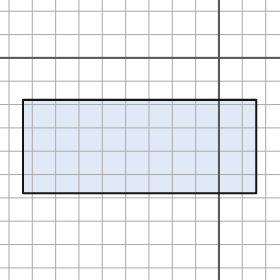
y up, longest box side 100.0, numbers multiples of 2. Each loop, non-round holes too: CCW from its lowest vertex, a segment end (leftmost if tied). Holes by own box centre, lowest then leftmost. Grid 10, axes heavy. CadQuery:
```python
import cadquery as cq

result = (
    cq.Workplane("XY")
    .moveTo(-84.0, -58.0)
    .lineTo(16.0, -58.0)
    .lineTo(16.0, -18.0)
    .lineTo(-84.0, -18.0)
    .close()
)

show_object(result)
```